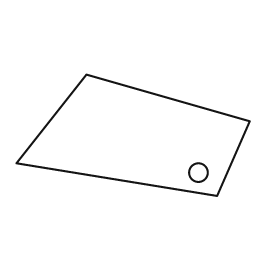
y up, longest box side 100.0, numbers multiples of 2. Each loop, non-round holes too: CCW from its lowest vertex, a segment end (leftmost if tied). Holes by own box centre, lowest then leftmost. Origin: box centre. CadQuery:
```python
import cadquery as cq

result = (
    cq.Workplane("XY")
    .moveTo(36.0, -26.0)
    .lineTo(50.0, 6.0)
    .lineTo(-20.0, 26.0)
    .lineTo(-50.0, -12.0)
    .close()
    .moveTo(28.0, -16.0)
    .circle(4.0)
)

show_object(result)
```